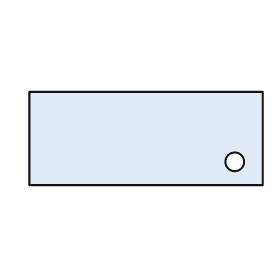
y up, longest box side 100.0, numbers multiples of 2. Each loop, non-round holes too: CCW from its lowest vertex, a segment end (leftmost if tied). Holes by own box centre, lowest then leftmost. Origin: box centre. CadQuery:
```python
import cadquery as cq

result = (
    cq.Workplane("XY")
    .moveTo(-50.0, -20.0)
    .lineTo(50.0, -20.0)
    .lineTo(50.0, 20.0)
    .lineTo(-50.0, 20.0)
    .close()
    .moveTo(38.0, -10.0)
    .circle(4.0)
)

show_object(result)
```